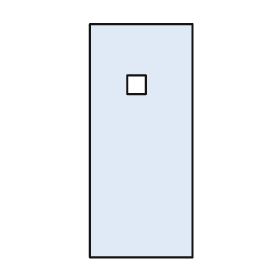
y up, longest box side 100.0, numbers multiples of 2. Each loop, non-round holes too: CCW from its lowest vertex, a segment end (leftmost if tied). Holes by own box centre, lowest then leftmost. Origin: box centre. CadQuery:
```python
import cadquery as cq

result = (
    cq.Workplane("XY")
    .moveTo(-22.0, -50.0)
    .lineTo(22.0, -50.0)
    .lineTo(22.0, 50.0)
    .lineTo(-22.0, 50.0)
    .close()
    .moveTo(-6.0, 20.0)
    .lineTo(2.0, 20.0)
    .lineTo(2.0, 28.0)
    .lineTo(-6.0, 28.0)
    .close()
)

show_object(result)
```